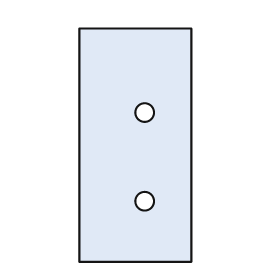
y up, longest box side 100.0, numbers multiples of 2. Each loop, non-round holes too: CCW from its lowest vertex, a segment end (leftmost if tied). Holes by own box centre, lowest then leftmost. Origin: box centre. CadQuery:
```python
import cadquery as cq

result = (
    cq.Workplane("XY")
    .moveTo(-24.0, -50.0)
    .lineTo(24.0, -50.0)
    .lineTo(24.0, 50.0)
    .lineTo(-24.0, 50.0)
    .close()
    .moveTo(4.0, -24.0)
    .circle(4.0)
    .moveTo(4.0, 14.0)
    .circle(4.0)
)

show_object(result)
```